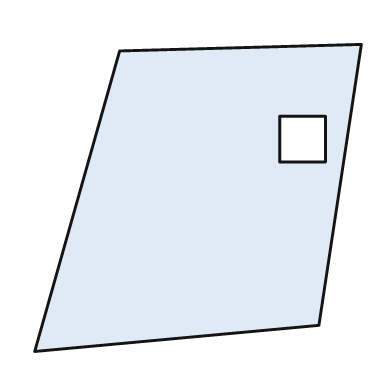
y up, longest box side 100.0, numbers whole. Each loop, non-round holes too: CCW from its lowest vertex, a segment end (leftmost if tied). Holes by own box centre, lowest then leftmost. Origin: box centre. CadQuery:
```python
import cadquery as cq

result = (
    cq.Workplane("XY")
    .moveTo(-50.0, -47.0)
    .lineTo(37.0, -39.0)
    .lineTo(50.0, 47.0)
    .lineTo(-24.0, 45.0)
    .close()
    .moveTo(25.0, 11.0)
    .lineTo(39.0, 11.0)
    .lineTo(39.0, 25.0)
    .lineTo(25.0, 25.0)
    .close()
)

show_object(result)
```